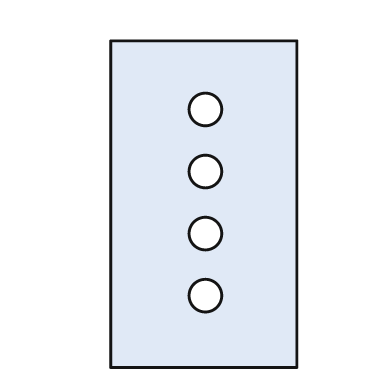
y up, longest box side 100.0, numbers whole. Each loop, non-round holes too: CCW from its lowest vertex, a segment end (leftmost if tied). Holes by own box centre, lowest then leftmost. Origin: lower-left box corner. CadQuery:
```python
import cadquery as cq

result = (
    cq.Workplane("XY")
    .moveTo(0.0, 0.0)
    .lineTo(57.0, 0.0)
    .lineTo(57.0, 100.0)
    .lineTo(0.0, 100.0)
    .close()
    .moveTo(29.0, 22.0)
    .circle(5.0)
    .moveTo(29.0, 41.0)
    .circle(5.0)
    .moveTo(29.0, 60.0)
    .circle(5.0)
    .moveTo(29.0, 79.0)
    .circle(5.0)
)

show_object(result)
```